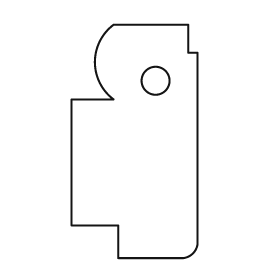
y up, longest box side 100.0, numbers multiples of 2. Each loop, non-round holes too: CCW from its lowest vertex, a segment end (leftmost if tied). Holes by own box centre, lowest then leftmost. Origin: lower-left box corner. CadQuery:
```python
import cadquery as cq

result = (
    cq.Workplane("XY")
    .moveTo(20.0, 0.0)
    .lineTo(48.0, 0.0)
    .threePointArc((52.0, 2.0), (54.0, 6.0))
    .lineTo(54.0, 88.0)
    .lineTo(50.0, 88.0)
    .lineTo(50.0, 100.0)
    .lineTo(18.0, 100.0)
    .threePointArc((10.0, 84.0), (18.0, 68.0))
    .lineTo(0.0, 68.0)
    .lineTo(0.0, 14.0)
    .lineTo(20.0, 14.0)
    .close()
    .moveTo(36.0, 76.0)
    .circle(6.0)
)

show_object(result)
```